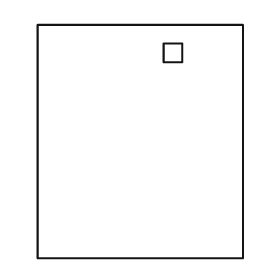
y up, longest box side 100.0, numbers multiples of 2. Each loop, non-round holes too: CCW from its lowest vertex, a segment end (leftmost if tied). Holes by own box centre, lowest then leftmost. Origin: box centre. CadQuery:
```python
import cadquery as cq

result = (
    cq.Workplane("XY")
    .moveTo(-44.0, -50.0)
    .lineTo(44.0, -50.0)
    .lineTo(44.0, 50.0)
    .lineTo(-44.0, 50.0)
    .close()
    .moveTo(10.0, 34.0)
    .lineTo(18.0, 34.0)
    .lineTo(18.0, 42.0)
    .lineTo(10.0, 42.0)
    .close()
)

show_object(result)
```